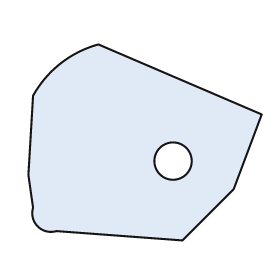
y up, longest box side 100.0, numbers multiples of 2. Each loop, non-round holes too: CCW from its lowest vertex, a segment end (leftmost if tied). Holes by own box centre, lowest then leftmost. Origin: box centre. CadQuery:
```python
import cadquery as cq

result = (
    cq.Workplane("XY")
    .moveTo(16.0, -42.0)
    .lineTo(38.0, -20.0)
    .lineTo(50.0, 12.0)
    .lineTo(-20.0, 42.0)
    .threePointArc((-36.0, 34.0), (-48.0, 20.0))
    .lineTo(-50.0, -14.0)
    .lineTo(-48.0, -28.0)
    .threePointArc((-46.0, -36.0), (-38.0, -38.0))
    .close()
    .moveTo(12.0, -8.0)
    .circle(8.0)
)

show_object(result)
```